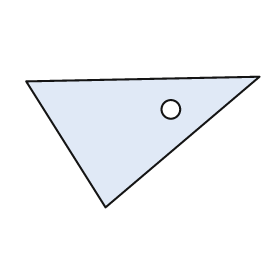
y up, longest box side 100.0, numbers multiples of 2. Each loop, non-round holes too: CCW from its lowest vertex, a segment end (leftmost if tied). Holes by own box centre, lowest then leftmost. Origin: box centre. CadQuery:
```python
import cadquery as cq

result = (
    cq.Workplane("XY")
    .moveTo(-16.0, -28.0)
    .lineTo(50.0, 28.0)
    .lineTo(-50.0, 26.0)
    .close()
    .moveTo(12.0, 14.0)
    .circle(4.0)
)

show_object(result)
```